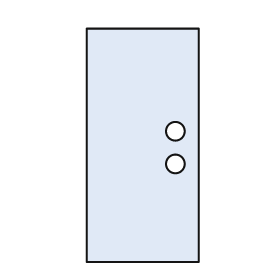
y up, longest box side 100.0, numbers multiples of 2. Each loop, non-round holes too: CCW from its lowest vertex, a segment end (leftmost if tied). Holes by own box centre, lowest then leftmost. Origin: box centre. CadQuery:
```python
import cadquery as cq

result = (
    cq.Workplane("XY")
    .moveTo(-24.0, -50.0)
    .lineTo(24.0, -50.0)
    .lineTo(24.0, 50.0)
    .lineTo(-24.0, 50.0)
    .close()
    .moveTo(14.0, -8.0)
    .circle(4.0)
    .moveTo(14.0, 6.0)
    .circle(4.0)
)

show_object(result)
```